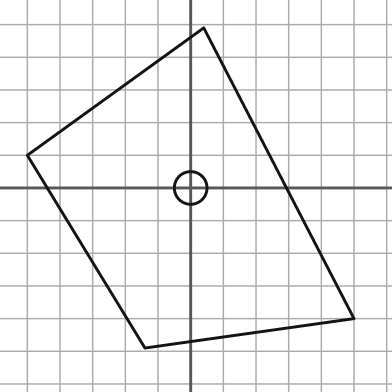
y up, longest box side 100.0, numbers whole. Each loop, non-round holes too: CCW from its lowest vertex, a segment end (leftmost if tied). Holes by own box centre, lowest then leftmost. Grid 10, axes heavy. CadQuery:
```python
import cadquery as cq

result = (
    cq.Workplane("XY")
    .moveTo(-14.0, -49.0)
    .lineTo(50.0, -40.0)
    .lineTo(4.0, 49.0)
    .lineTo(-50.0, 10.0)
    .close()
    .moveTo(0.0, 0.0)
    .circle(5.0)
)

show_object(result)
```